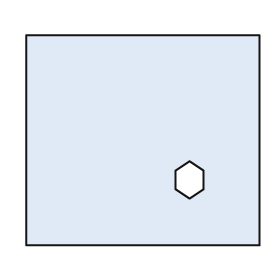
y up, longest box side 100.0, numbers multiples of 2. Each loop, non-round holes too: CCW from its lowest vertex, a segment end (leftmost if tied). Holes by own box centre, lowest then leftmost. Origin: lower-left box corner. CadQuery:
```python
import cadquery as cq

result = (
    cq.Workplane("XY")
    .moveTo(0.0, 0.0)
    .lineTo(100.0, 0.0)
    .lineTo(100.0, 90.0)
    .lineTo(0.0, 90.0)
    .close()
    .moveTo(70.0, 20.0)
    .lineTo(76.0, 24.0)
    .lineTo(76.0, 32.0)
    .lineTo(70.0, 36.0)
    .lineTo(64.0, 32.0)
    .lineTo(64.0, 24.0)
    .close()
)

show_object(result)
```